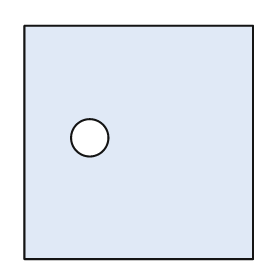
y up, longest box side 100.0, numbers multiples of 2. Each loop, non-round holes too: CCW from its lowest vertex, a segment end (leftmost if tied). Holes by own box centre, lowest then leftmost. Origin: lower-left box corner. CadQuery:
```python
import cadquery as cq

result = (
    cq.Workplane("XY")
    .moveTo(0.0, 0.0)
    .lineTo(98.0, 0.0)
    .lineTo(98.0, 100.0)
    .lineTo(0.0, 100.0)
    .close()
    .moveTo(28.0, 52.0)
    .circle(8.0)
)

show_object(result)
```